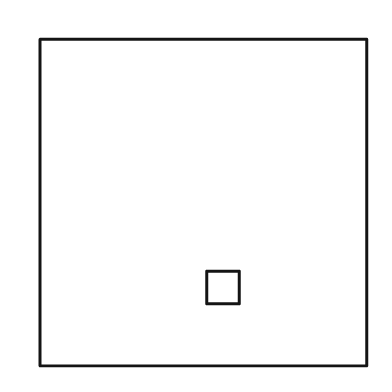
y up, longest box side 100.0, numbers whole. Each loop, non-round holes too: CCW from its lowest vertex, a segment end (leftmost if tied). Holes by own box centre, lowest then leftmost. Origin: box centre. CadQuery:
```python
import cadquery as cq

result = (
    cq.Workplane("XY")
    .moveTo(-50.0, -50.0)
    .lineTo(50.0, -50.0)
    .lineTo(50.0, 50.0)
    .lineTo(-50.0, 50.0)
    .close()
    .moveTo(1.0, -31.0)
    .lineTo(11.0, -31.0)
    .lineTo(11.0, -21.0)
    .lineTo(1.0, -21.0)
    .close()
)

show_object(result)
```